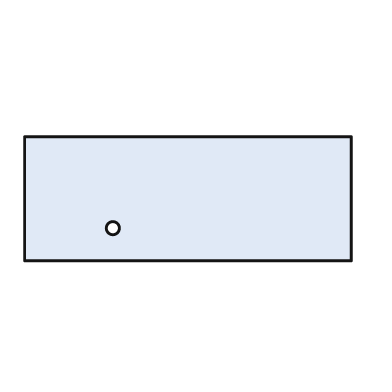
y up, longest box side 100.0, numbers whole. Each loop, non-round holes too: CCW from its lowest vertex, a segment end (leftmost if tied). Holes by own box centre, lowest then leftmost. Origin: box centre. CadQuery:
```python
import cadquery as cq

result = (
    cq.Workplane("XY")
    .moveTo(-50.0, -19.0)
    .lineTo(50.0, -19.0)
    .lineTo(50.0, 19.0)
    .lineTo(-50.0, 19.0)
    .close()
    .moveTo(-23.0, -9.0)
    .circle(2.0)
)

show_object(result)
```